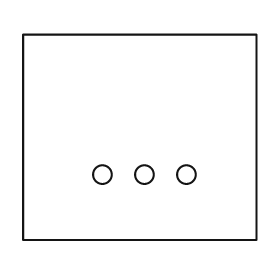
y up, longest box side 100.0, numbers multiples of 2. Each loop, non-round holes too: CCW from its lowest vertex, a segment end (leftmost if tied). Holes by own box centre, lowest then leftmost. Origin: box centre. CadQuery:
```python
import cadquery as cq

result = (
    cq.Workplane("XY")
    .moveTo(-50.0, -44.0)
    .lineTo(50.0, -44.0)
    .lineTo(50.0, 44.0)
    .lineTo(-50.0, 44.0)
    .close()
    .moveTo(-16.0, -16.0)
    .circle(4.0)
    .moveTo(2.0, -16.0)
    .circle(4.0)
    .moveTo(20.0, -16.0)
    .circle(4.0)
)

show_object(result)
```